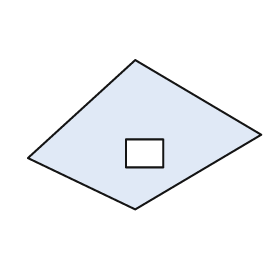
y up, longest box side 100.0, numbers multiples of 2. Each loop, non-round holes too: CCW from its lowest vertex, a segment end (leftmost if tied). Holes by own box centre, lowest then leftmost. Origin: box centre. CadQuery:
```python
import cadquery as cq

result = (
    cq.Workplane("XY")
    .moveTo(-4.0, -32.0)
    .lineTo(50.0, 0.0)
    .lineTo(-4.0, 32.0)
    .lineTo(-50.0, -10.0)
    .close()
    .moveTo(-8.0, -14.0)
    .lineTo(8.0, -14.0)
    .lineTo(8.0, -2.0)
    .lineTo(-8.0, -2.0)
    .close()
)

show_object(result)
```